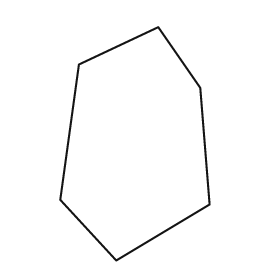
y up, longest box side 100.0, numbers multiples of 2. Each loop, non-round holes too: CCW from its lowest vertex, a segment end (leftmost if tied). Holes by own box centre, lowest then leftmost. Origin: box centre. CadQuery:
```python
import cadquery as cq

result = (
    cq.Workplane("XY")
    .moveTo(-8.0, -50.0)
    .lineTo(32.0, -26.0)
    .lineTo(28.0, 24.0)
    .lineTo(10.0, 50.0)
    .lineTo(-24.0, 34.0)
    .lineTo(-32.0, -24.0)
    .close()
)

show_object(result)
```